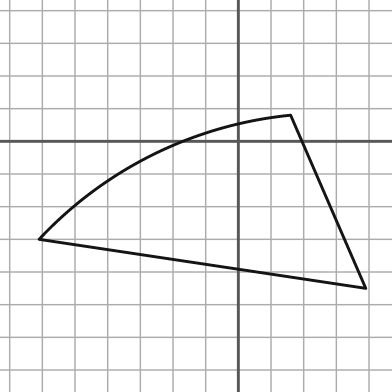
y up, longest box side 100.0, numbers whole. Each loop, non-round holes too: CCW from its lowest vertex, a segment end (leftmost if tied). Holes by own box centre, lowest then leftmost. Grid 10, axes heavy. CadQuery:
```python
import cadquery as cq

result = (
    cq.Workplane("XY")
    .moveTo(39.0, -45.0)
    .lineTo(16.0, 8.0)
    .threePointArc((-26.0, -4.0), (-61.0, -30.0))
    .close()
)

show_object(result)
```